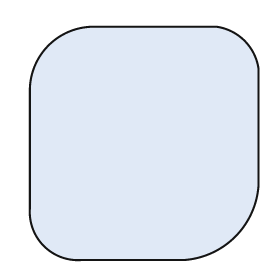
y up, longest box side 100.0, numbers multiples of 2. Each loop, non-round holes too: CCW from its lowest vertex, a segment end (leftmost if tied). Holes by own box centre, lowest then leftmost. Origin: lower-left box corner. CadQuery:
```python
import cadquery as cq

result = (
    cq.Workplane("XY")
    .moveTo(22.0, 0.0)
    .lineTo(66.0, 0.0)
    .threePointArc((88.0, 10.0), (98.0, 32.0))
    .lineTo(98.0, 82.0)
    .threePointArc((92.0, 94.0), (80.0, 100.0))
    .lineTo(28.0, 100.0)
    .threePointArc((8.0, 92.0), (0.0, 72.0))
    .lineTo(0.0, 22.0)
    .threePointArc((6.0, 6.0), (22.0, 0.0))
    .close()
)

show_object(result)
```